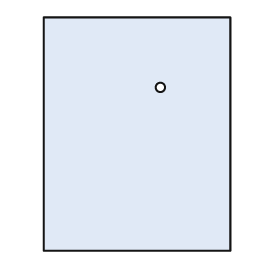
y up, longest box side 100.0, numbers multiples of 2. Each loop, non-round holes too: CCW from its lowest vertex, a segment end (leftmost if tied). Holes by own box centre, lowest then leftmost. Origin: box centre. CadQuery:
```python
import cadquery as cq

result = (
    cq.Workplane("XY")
    .moveTo(-40.0, -50.0)
    .lineTo(40.0, -50.0)
    .lineTo(40.0, 50.0)
    .lineTo(-40.0, 50.0)
    .close()
    .moveTo(10.0, 20.0)
    .circle(2.0)
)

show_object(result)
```